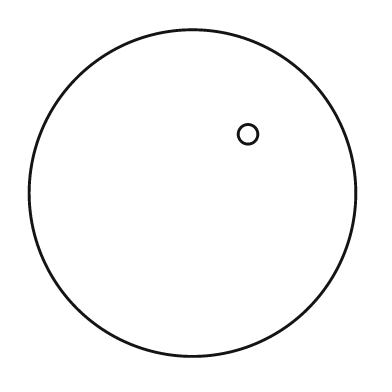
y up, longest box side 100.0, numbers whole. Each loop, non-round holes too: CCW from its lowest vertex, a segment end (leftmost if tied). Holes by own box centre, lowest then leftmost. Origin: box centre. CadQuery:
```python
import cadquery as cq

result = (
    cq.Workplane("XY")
    .moveTo(0.0, 0.0)
    .circle(50.0)
    .moveTo(17.0, 18.0)
    .circle(3.0)
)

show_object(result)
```